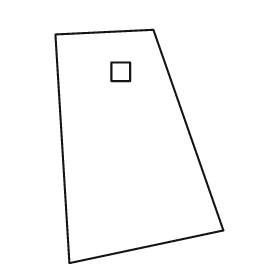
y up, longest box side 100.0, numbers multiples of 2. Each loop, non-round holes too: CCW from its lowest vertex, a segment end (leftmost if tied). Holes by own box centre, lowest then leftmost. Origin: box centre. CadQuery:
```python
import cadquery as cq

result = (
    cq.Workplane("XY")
    .moveTo(-30.0, -50.0)
    .lineTo(36.0, -36.0)
    .lineTo(6.0, 50.0)
    .lineTo(-36.0, 48.0)
    .close()
    .moveTo(-12.0, 28.0)
    .lineTo(-4.0, 28.0)
    .lineTo(-4.0, 36.0)
    .lineTo(-12.0, 36.0)
    .close()
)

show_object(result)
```